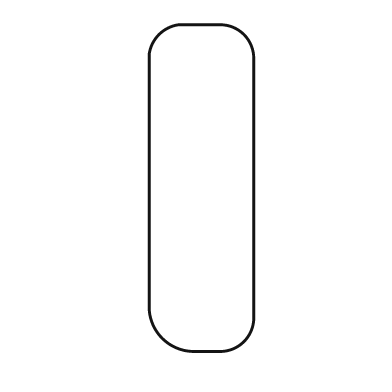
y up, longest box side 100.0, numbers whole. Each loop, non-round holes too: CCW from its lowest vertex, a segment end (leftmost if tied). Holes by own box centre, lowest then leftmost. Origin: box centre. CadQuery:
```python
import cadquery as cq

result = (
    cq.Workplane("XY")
    .moveTo(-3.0, -50.0)
    .lineTo(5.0, -50.0)
    .threePointArc((13.0, -47.0), (16.0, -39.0))
    .lineTo(16.0, 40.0)
    .threePointArc((13.0, 47.0), (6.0, 50.0))
    .lineTo(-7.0, 50.0)
    .threePointArc((-13.0, 47.0), (-16.0, 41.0))
    .lineTo(-16.0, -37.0)
    .threePointArc((-12.0, -46.0), (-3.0, -50.0))
    .close()
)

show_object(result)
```